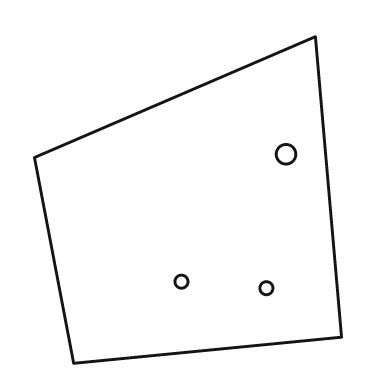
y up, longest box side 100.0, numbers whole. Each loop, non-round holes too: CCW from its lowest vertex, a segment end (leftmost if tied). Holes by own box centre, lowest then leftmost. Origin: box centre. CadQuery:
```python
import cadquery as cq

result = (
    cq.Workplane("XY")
    .moveTo(-35.0, -50.0)
    .lineTo(47.0, -42.0)
    .lineTo(39.0, 50.0)
    .lineTo(-47.0, 13.0)
    .close()
    .moveTo(24.0, -27.0)
    .circle(2.0)
    .moveTo(-2.0, -25.0)
    .circle(2.0)
    .moveTo(30.0, 14.0)
    .circle(3.0)
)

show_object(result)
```